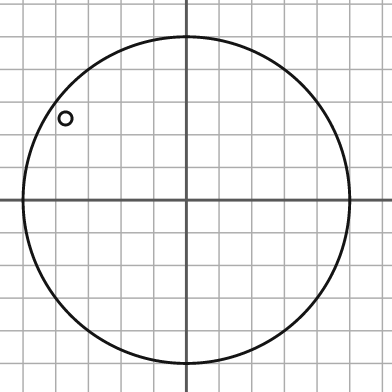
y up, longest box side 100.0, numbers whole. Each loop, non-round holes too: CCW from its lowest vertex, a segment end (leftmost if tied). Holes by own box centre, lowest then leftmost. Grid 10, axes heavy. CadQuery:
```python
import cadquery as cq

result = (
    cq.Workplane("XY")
    .moveTo(0.0, 0.0)
    .circle(50.0)
    .moveTo(-37.0, 25.0)
    .circle(2.0)
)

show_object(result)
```